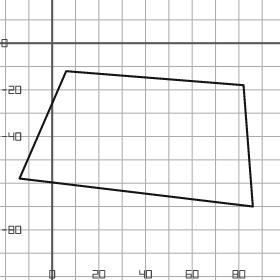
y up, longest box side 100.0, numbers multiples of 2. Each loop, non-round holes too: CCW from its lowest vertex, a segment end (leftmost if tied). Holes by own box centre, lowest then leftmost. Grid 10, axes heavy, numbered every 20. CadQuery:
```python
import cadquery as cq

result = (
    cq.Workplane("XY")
    .moveTo(86.0, -70.0)
    .lineTo(82.0, -18.0)
    .lineTo(6.0, -12.0)
    .lineTo(-14.0, -58.0)
    .close()
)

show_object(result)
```